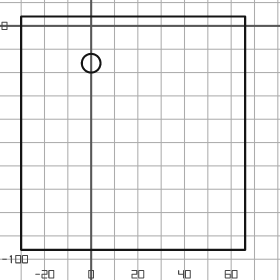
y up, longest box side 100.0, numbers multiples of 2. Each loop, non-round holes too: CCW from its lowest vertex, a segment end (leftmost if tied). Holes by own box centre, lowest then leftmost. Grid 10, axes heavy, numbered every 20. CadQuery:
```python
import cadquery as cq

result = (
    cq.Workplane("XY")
    .moveTo(-30.0, -96.0)
    .lineTo(66.0, -96.0)
    .lineTo(66.0, 4.0)
    .lineTo(-30.0, 4.0)
    .close()
    .moveTo(0.0, -16.0)
    .circle(4.0)
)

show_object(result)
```